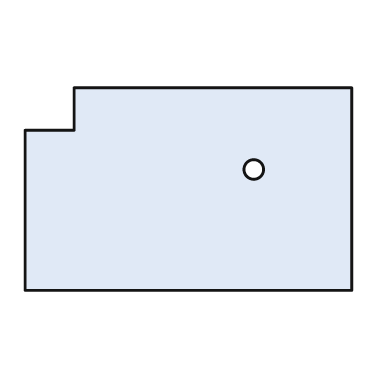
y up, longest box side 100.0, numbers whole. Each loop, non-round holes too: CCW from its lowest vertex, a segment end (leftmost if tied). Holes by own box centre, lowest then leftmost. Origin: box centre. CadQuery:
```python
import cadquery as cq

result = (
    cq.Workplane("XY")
    .moveTo(-50.0, -31.0)
    .lineTo(50.0, -31.0)
    .lineTo(50.0, 31.0)
    .lineTo(-35.0, 31.0)
    .lineTo(-35.0, 18.0)
    .lineTo(-50.0, 18.0)
    .close()
    .moveTo(20.0, 6.0)
    .circle(3.0)
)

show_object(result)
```